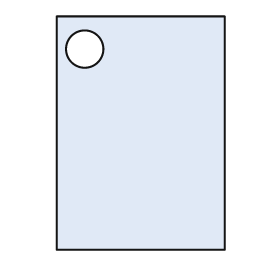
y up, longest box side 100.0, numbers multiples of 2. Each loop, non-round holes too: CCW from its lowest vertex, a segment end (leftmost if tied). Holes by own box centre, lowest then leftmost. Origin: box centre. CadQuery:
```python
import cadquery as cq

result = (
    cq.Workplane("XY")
    .moveTo(-36.0, -50.0)
    .lineTo(36.0, -50.0)
    .lineTo(36.0, 50.0)
    .lineTo(-36.0, 50.0)
    .close()
    .moveTo(-24.0, 36.0)
    .circle(8.0)
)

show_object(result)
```